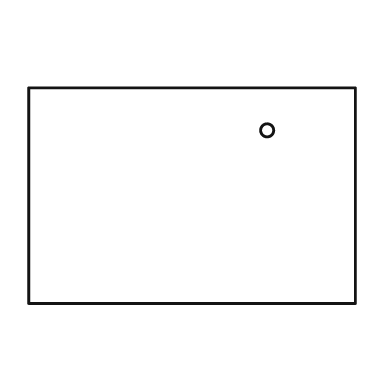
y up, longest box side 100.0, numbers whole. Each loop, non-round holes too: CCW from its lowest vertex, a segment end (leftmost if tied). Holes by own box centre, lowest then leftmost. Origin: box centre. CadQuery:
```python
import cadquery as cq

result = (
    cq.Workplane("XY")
    .moveTo(-50.0, -33.0)
    .lineTo(50.0, -33.0)
    .lineTo(50.0, 33.0)
    .lineTo(-50.0, 33.0)
    .close()
    .moveTo(23.0, 20.0)
    .circle(2.0)
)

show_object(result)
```